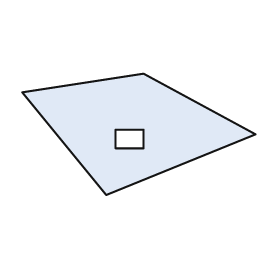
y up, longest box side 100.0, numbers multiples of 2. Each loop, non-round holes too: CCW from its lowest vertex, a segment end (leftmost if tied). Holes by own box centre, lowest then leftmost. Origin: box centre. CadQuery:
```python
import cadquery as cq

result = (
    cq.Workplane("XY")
    .moveTo(-14.0, -26.0)
    .lineTo(50.0, 0.0)
    .lineTo(2.0, 26.0)
    .lineTo(-50.0, 18.0)
    .close()
    .moveTo(-10.0, -6.0)
    .lineTo(2.0, -6.0)
    .lineTo(2.0, 2.0)
    .lineTo(-10.0, 2.0)
    .close()
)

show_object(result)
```